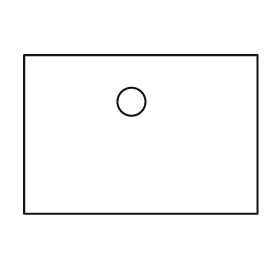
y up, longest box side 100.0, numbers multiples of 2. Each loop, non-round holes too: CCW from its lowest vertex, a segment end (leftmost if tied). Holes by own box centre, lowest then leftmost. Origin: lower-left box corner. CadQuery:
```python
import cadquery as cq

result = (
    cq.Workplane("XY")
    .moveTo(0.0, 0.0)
    .lineTo(100.0, 0.0)
    .lineTo(100.0, 68.0)
    .lineTo(0.0, 68.0)
    .close()
    .moveTo(46.0, 48.0)
    .circle(6.0)
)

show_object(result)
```